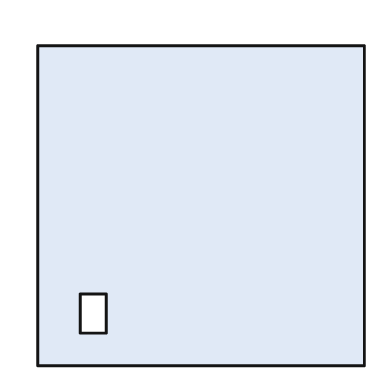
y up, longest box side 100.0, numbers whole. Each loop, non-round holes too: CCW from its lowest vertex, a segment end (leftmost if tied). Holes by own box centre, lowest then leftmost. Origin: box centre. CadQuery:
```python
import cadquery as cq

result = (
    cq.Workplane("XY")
    .moveTo(-50.0, -49.0)
    .lineTo(50.0, -49.0)
    .lineTo(50.0, 49.0)
    .lineTo(-50.0, 49.0)
    .close()
    .moveTo(-37.0, -39.0)
    .lineTo(-29.0, -39.0)
    .lineTo(-29.0, -27.0)
    .lineTo(-37.0, -27.0)
    .close()
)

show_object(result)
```